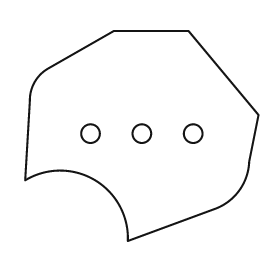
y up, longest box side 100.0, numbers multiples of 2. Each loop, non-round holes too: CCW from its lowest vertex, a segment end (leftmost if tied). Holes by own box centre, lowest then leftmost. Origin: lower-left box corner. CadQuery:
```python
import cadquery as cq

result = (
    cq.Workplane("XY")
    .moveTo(44.0, 0.0)
    .lineTo(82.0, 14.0)
    .threePointArc((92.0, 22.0), (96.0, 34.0))
    .lineTo(100.0, 54.0)
    .lineTo(70.0, 90.0)
    .lineTo(38.0, 90.0)
    .lineTo(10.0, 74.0)
    .threePointArc((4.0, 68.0), (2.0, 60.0))
    .lineTo(0.0, 26.0)
    .threePointArc((30.0, 26.0), (44.0, 0.0))
    .close()
    .moveTo(28.0, 46.0)
    .circle(4.0)
    .moveTo(50.0, 46.0)
    .circle(4.0)
    .moveTo(72.0, 46.0)
    .circle(4.0)
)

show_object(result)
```